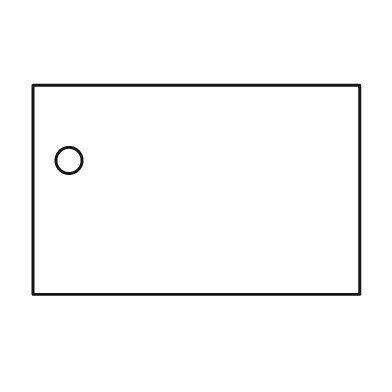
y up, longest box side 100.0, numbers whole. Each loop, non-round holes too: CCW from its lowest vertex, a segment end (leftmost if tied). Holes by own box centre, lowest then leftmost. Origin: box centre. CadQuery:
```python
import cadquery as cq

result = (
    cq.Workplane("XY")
    .moveTo(-50.0, -32.0)
    .lineTo(50.0, -32.0)
    .lineTo(50.0, 32.0)
    .lineTo(-50.0, 32.0)
    .close()
    .moveTo(-39.0, 9.0)
    .circle(4.0)
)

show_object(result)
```